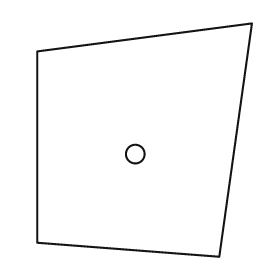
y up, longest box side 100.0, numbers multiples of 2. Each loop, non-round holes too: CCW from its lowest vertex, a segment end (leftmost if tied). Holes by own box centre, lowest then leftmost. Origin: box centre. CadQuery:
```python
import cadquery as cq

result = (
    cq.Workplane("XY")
    .moveTo(32.0, -50.0)
    .lineTo(46.0, 50.0)
    .lineTo(-46.0, 38.0)
    .lineTo(-46.0, -44.0)
    .close()
    .moveTo(-4.0, -6.0)
    .circle(4.0)
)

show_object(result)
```